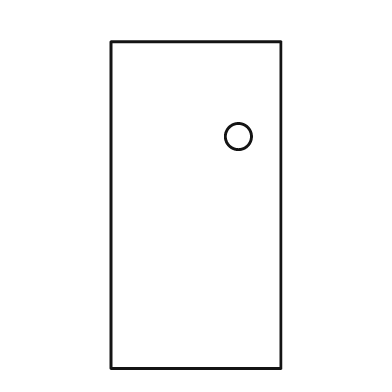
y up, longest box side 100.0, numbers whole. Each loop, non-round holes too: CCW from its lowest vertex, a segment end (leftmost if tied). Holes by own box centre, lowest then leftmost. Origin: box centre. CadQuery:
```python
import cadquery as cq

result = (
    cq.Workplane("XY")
    .moveTo(-26.0, -50.0)
    .lineTo(26.0, -50.0)
    .lineTo(26.0, 50.0)
    .lineTo(-26.0, 50.0)
    .close()
    .moveTo(13.0, 21.0)
    .circle(4.0)
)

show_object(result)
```